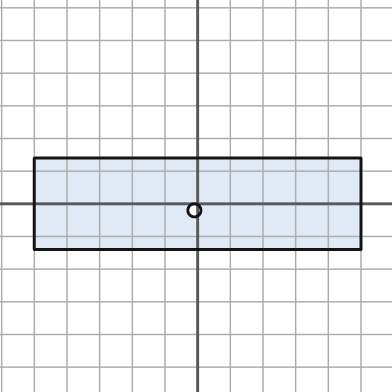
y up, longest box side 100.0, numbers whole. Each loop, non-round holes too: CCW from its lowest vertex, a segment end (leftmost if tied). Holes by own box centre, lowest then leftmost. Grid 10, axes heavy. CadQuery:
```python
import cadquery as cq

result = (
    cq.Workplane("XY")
    .moveTo(-50.0, -14.0)
    .lineTo(50.0, -14.0)
    .lineTo(50.0, 14.0)
    .lineTo(-50.0, 14.0)
    .close()
    .moveTo(-1.0, -2.0)
    .circle(2.0)
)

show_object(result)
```